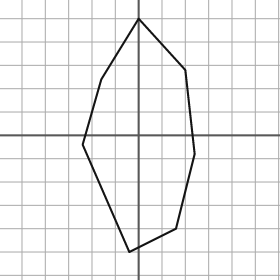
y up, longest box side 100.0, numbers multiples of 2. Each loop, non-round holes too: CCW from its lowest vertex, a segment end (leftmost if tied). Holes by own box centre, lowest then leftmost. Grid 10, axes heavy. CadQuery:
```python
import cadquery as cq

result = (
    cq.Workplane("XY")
    .moveTo(-4.0, -50.0)
    .lineTo(16.0, -40.0)
    .lineTo(24.0, -8.0)
    .lineTo(20.0, 28.0)
    .lineTo(0.0, 50.0)
    .lineTo(-16.0, 24.0)
    .lineTo(-24.0, -4.0)
    .close()
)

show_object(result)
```